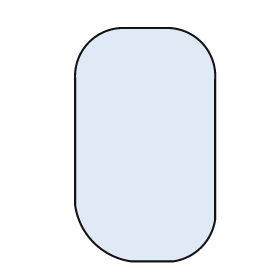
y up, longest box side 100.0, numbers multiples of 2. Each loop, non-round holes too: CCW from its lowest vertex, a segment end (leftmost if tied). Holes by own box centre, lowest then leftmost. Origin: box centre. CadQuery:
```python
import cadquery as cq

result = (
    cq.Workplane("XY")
    .moveTo(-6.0, -50.0)
    .lineTo(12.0, -50.0)
    .threePointArc((24.0, -44.0), (30.0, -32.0))
    .lineTo(30.0, 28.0)
    .threePointArc((24.0, 44.0), (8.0, 50.0))
    .lineTo(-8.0, 50.0)
    .threePointArc((-24.0, 44.0), (-30.0, 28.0))
    .lineTo(-30.0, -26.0)
    .threePointArc((-22.0, -42.0), (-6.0, -50.0))
    .close()
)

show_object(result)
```